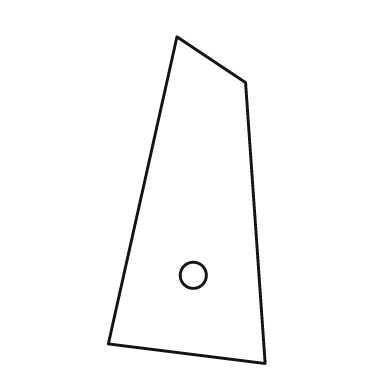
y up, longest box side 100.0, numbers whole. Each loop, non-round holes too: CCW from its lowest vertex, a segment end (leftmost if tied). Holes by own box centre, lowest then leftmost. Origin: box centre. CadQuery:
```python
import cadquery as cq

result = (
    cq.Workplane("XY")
    .moveTo(24.0, -50.0)
    .lineTo(18.0, 36.0)
    .lineTo(-3.0, 50.0)
    .lineTo(-24.0, -44.0)
    .close()
    .moveTo(2.0, -23.0)
    .circle(4.0)
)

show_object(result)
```